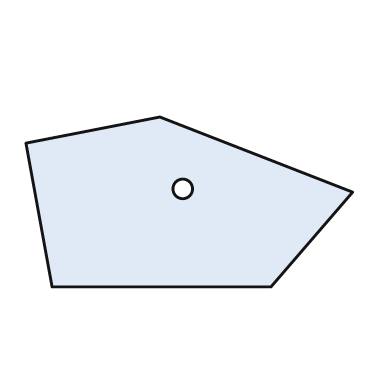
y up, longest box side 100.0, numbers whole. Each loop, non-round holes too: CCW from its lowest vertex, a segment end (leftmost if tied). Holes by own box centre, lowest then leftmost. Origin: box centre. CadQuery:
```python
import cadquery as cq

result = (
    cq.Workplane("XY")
    .moveTo(-42.0, -26.0)
    .lineTo(25.0, -26.0)
    .lineTo(50.0, 3.0)
    .lineTo(-9.0, 26.0)
    .lineTo(-50.0, 18.0)
    .close()
    .moveTo(-2.0, 4.0)
    .circle(3.0)
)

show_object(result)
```